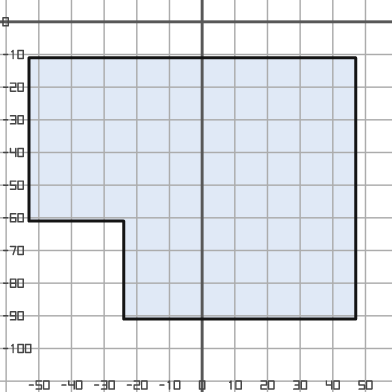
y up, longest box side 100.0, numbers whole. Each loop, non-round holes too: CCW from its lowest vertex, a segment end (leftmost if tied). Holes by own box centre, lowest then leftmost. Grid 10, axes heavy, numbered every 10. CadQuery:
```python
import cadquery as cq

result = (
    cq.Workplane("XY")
    .moveTo(-24.0, -91.0)
    .lineTo(47.0, -91.0)
    .lineTo(47.0, -11.0)
    .lineTo(-53.0, -11.0)
    .lineTo(-53.0, -61.0)
    .lineTo(-24.0, -61.0)
    .close()
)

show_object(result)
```